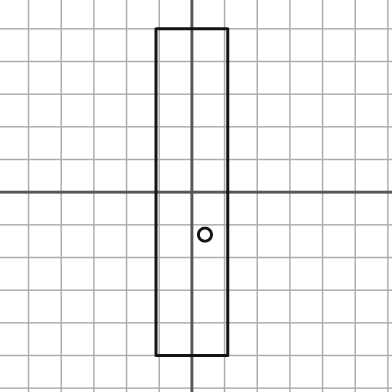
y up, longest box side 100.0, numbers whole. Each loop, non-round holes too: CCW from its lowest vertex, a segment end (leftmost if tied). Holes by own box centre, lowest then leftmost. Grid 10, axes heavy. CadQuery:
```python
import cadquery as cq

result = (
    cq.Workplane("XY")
    .moveTo(-11.0, -50.0)
    .lineTo(11.0, -50.0)
    .lineTo(11.0, 50.0)
    .lineTo(-11.0, 50.0)
    .close()
    .moveTo(4.0, -13.0)
    .circle(2.0)
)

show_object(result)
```